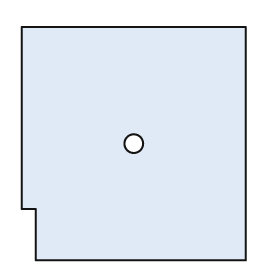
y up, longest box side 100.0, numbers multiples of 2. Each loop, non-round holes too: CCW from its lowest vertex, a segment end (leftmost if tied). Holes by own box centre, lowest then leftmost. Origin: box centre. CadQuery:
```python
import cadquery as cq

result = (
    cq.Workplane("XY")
    .moveTo(-42.0, -50.0)
    .lineTo(48.0, -50.0)
    .lineTo(48.0, 50.0)
    .lineTo(-48.0, 50.0)
    .lineTo(-48.0, -28.0)
    .lineTo(-42.0, -28.0)
    .close()
    .moveTo(0.0, 0.0)
    .circle(4.0)
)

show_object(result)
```